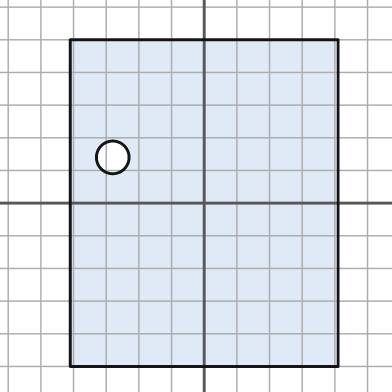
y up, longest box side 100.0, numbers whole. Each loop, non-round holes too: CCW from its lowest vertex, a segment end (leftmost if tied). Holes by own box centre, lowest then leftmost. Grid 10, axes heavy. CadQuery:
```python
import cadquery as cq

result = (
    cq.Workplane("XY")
    .moveTo(-41.0, -50.0)
    .lineTo(41.0, -50.0)
    .lineTo(41.0, 50.0)
    .lineTo(-41.0, 50.0)
    .close()
    .moveTo(-28.0, 14.0)
    .circle(5.0)
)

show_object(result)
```